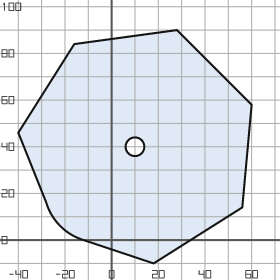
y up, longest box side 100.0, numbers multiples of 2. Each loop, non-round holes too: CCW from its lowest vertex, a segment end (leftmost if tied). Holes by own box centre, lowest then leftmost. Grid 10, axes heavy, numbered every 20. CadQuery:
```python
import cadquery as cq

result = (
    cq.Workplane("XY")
    .moveTo(18.0, -10.0)
    .lineTo(56.0, 14.0)
    .lineTo(60.0, 58.0)
    .lineTo(28.0, 90.0)
    .lineTo(-16.0, 84.0)
    .lineTo(-40.0, 46.0)
    .lineTo(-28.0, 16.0)
    .threePointArc((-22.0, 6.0), (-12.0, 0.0))
    .close()
    .moveTo(10.0, 40.0)
    .circle(4.0)
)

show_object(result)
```